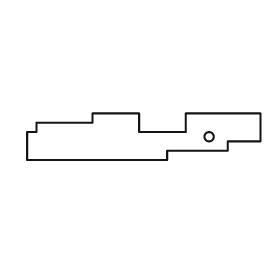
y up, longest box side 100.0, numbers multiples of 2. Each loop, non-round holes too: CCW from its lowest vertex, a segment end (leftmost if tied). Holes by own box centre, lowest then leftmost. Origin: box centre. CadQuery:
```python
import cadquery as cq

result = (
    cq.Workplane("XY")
    .moveTo(-50.0, -10.0)
    .lineTo(10.0, -10.0)
    .lineTo(10.0, -6.0)
    .lineTo(36.0, -6.0)
    .lineTo(36.0, -2.0)
    .lineTo(50.0, -2.0)
    .lineTo(50.0, 10.0)
    .lineTo(18.0, 10.0)
    .lineTo(18.0, 2.0)
    .lineTo(-2.0, 2.0)
    .lineTo(-2.0, 10.0)
    .lineTo(-22.0, 10.0)
    .lineTo(-22.0, 6.0)
    .lineTo(-46.0, 6.0)
    .lineTo(-46.0, 2.0)
    .lineTo(-50.0, 2.0)
    .close()
    .moveTo(28.0, 0.0)
    .circle(2.0)
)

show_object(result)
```